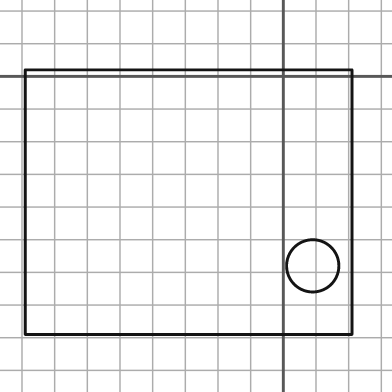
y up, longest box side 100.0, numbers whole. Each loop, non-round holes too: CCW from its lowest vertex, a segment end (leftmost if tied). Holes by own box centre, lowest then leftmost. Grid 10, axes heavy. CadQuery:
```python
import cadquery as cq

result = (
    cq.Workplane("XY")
    .moveTo(-79.0, -79.0)
    .lineTo(21.0, -79.0)
    .lineTo(21.0, 2.0)
    .lineTo(-79.0, 2.0)
    .close()
    .moveTo(9.0, -58.0)
    .circle(8.0)
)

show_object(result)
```